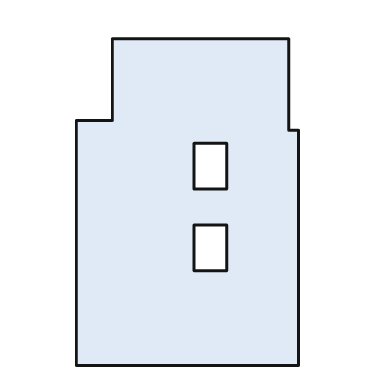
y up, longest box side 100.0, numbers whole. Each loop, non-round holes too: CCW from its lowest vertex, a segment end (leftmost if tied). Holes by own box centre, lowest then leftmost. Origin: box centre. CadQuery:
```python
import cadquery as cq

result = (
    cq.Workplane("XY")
    .moveTo(-34.0, -50.0)
    .lineTo(34.0, -50.0)
    .lineTo(34.0, 22.0)
    .lineTo(31.0, 22.0)
    .lineTo(31.0, 50.0)
    .lineTo(-23.0, 50.0)
    .lineTo(-23.0, 25.0)
    .lineTo(-34.0, 25.0)
    .close()
    .moveTo(2.0, -21.0)
    .lineTo(12.0, -21.0)
    .lineTo(12.0, -7.0)
    .lineTo(2.0, -7.0)
    .close()
    .moveTo(2.0, 4.0)
    .lineTo(12.0, 4.0)
    .lineTo(12.0, 18.0)
    .lineTo(2.0, 18.0)
    .close()
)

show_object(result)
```